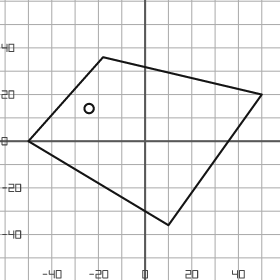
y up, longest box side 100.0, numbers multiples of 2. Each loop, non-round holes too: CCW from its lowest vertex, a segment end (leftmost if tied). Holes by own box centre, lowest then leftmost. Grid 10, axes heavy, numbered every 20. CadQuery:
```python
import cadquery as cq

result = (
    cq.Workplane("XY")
    .moveTo(10.0, -36.0)
    .lineTo(50.0, 20.0)
    .lineTo(-18.0, 36.0)
    .lineTo(-50.0, 0.0)
    .close()
    .moveTo(-24.0, 14.0)
    .circle(2.0)
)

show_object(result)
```